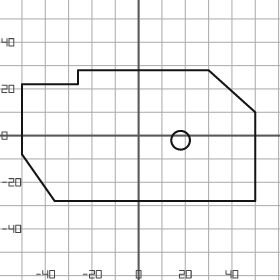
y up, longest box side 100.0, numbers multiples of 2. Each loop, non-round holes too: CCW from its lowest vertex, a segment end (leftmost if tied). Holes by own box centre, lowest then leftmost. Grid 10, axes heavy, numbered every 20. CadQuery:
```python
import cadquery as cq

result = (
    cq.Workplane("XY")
    .moveTo(-36.0, -28.0)
    .lineTo(50.0, -28.0)
    .lineTo(50.0, 10.0)
    .lineTo(30.0, 28.0)
    .lineTo(-26.0, 28.0)
    .lineTo(-26.0, 22.0)
    .lineTo(-50.0, 22.0)
    .lineTo(-50.0, -8.0)
    .close()
    .moveTo(18.0, -2.0)
    .circle(4.0)
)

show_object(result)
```